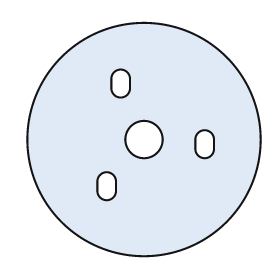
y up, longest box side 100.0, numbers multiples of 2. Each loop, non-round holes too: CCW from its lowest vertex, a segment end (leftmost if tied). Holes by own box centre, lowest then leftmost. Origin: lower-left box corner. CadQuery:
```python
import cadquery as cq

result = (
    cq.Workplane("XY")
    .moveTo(50.0, 50.0)
    .circle(50.0)
    .moveTo(30.0, 28.0)
    .threePointArc((34.0, 24.0), (38.0, 28.0))
    .lineTo(38.0, 32.0)
    .threePointArc((34.0, 36.0), (30.0, 32.0))
    .close()
    .moveTo(72.0, 46.0)
    .threePointArc((76.0, 42.0), (80.0, 46.0))
    .lineTo(80.0, 50.0)
    .threePointArc((76.0, 54.0), (72.0, 50.0))
    .close()
    .moveTo(50.0, 50.0)
    .circle(8.0)
    .moveTo(36.0, 72.0)
    .threePointArc((40.0, 68.0), (44.0, 72.0))
    .lineTo(44.0, 76.0)
    .threePointArc((40.0, 80.0), (36.0, 76.0))
    .close()
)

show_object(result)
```